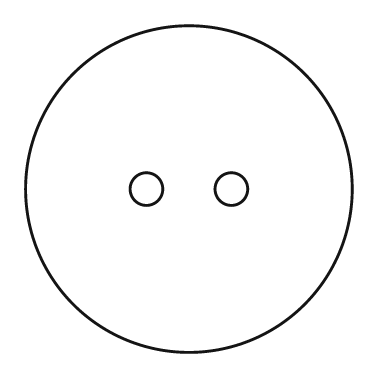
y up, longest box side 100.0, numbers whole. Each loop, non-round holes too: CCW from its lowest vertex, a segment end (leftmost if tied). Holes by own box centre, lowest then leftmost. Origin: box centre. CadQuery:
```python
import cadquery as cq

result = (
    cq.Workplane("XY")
    .moveTo(0.0, 0.0)
    .circle(50.0)
    .moveTo(-13.0, 0.0)
    .circle(5.0)
    .moveTo(13.0, 0.0)
    .circle(5.0)
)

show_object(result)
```